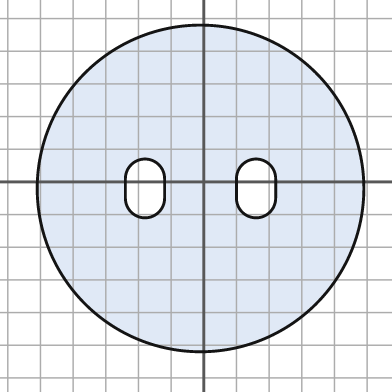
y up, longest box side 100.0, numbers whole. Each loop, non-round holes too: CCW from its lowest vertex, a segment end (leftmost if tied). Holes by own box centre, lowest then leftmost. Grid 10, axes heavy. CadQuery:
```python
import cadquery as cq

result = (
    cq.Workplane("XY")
    .moveTo(-1.0, -2.0)
    .circle(50.0)
    .moveTo(-24.0, -5.0)
    .threePointArc((-18.0, -11.0), (-12.0, -5.0))
    .lineTo(-12.0, 1.0)
    .threePointArc((-18.0, 7.0), (-24.0, 1.0))
    .close()
    .moveTo(10.0, -5.0)
    .threePointArc((16.0, -11.0), (22.0, -5.0))
    .lineTo(22.0, 1.0)
    .threePointArc((16.0, 7.0), (10.0, 1.0))
    .close()
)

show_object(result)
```